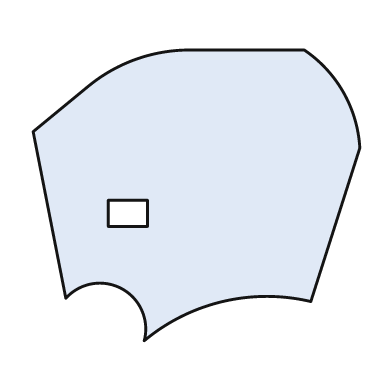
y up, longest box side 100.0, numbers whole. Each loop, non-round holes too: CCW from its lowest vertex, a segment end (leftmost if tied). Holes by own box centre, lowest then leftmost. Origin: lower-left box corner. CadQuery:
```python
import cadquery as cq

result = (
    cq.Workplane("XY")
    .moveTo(34.0, 0.0)
    .threePointArc((58.0, 12.0), (85.0, 12.0))
    .lineTo(100.0, 59.0)
    .threePointArc((95.0, 76.0), (83.0, 89.0))
    .lineTo(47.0, 89.0)
    .threePointArc((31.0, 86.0), (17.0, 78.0))
    .lineTo(0.0, 64.0)
    .lineTo(10.0, 13.0)
    .threePointArc((27.0, 16.0), (34.0, 0.0))
    .close()
    .moveTo(23.0, 35.0)
    .lineTo(35.0, 35.0)
    .lineTo(35.0, 43.0)
    .lineTo(23.0, 43.0)
    .close()
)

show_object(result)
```